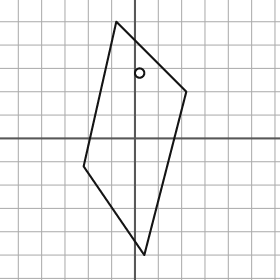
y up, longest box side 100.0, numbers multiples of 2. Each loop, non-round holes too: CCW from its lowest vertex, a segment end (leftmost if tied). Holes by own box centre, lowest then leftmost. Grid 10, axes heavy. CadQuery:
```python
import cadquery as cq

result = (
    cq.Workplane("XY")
    .moveTo(4.0, -50.0)
    .lineTo(22.0, 20.0)
    .lineTo(-8.0, 50.0)
    .lineTo(-22.0, -12.0)
    .close()
    .moveTo(2.0, 28.0)
    .circle(2.0)
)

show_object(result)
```